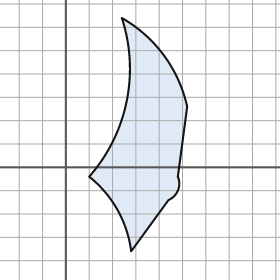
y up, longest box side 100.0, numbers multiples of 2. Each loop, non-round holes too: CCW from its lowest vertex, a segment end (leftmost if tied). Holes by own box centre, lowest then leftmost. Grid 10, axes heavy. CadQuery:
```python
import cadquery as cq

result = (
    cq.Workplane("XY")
    .moveTo(28.0, -36.0)
    .lineTo(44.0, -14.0)
    .threePointArc((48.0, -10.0), (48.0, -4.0))
    .lineTo(52.0, 26.0)
    .threePointArc((42.0, 48.0), (24.0, 64.0))
    .threePointArc((26.0, 28.0), (10.0, -4.0))
    .threePointArc((22.0, -18.0), (28.0, -36.0))
    .close()
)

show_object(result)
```